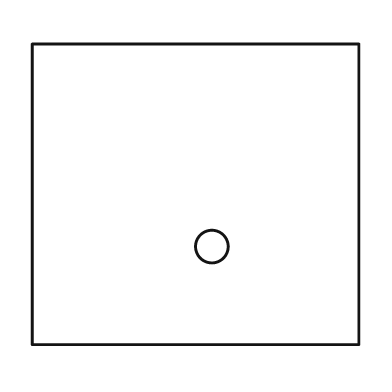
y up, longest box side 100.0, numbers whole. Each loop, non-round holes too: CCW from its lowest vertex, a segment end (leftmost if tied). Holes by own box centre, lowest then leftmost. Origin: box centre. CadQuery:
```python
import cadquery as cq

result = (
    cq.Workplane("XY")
    .moveTo(-50.0, -46.0)
    .lineTo(50.0, -46.0)
    .lineTo(50.0, 46.0)
    .lineTo(-50.0, 46.0)
    .close()
    .moveTo(5.0, -16.0)
    .circle(5.0)
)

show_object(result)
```